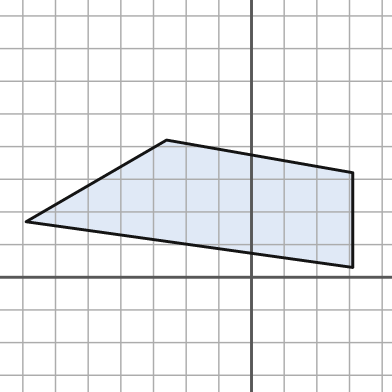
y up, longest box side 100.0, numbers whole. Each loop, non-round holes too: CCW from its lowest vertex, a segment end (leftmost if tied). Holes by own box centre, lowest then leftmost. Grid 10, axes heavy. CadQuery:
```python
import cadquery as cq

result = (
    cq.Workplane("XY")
    .moveTo(31.0, 3.0)
    .lineTo(31.0, 32.0)
    .lineTo(-26.0, 42.0)
    .lineTo(-69.0, 17.0)
    .close()
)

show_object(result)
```